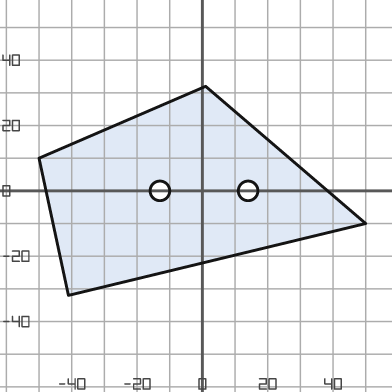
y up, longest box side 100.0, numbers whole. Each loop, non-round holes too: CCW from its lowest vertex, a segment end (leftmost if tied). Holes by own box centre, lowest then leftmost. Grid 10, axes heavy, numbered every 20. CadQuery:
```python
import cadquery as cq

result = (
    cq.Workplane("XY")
    .moveTo(-41.0, -32.0)
    .lineTo(50.0, -10.0)
    .lineTo(1.0, 32.0)
    .lineTo(-50.0, 10.0)
    .close()
    .moveTo(-13.0, 0.0)
    .circle(3.0)
    .moveTo(14.0, 0.0)
    .circle(3.0)
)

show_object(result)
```